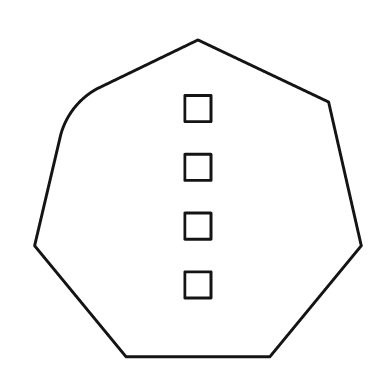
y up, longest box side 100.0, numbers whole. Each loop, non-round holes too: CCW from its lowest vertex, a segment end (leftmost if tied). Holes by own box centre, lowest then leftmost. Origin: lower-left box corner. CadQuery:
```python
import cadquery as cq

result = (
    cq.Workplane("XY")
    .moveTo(28.0, 0.0)
    .lineTo(72.0, 0.0)
    .lineTo(100.0, 34.0)
    .lineTo(90.0, 78.0)
    .lineTo(50.0, 97.0)
    .lineTo(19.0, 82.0)
    .threePointArc((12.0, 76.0), (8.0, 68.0))
    .lineTo(0.0, 34.0)
    .close()
    .moveTo(46.0, 18.0)
    .lineTo(54.0, 18.0)
    .lineTo(54.0, 26.0)
    .lineTo(46.0, 26.0)
    .close()
    .moveTo(46.0, 36.0)
    .lineTo(54.0, 36.0)
    .lineTo(54.0, 44.0)
    .lineTo(46.0, 44.0)
    .close()
    .moveTo(46.0, 54.0)
    .lineTo(54.0, 54.0)
    .lineTo(54.0, 62.0)
    .lineTo(46.0, 62.0)
    .close()
    .moveTo(46.0, 72.0)
    .lineTo(54.0, 72.0)
    .lineTo(54.0, 80.0)
    .lineTo(46.0, 80.0)
    .close()
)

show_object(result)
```